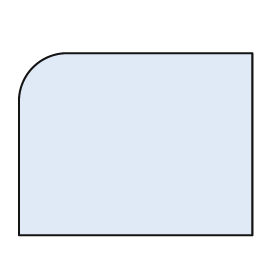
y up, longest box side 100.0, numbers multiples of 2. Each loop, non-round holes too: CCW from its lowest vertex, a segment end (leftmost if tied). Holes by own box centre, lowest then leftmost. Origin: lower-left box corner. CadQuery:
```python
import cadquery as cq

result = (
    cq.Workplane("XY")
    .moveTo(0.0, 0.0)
    .lineTo(100.0, 0.0)
    .lineTo(100.0, 78.0)
    .lineTo(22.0, 78.0)
    .threePointArc((6.0, 72.0), (0.0, 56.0))
    .close()
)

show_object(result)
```